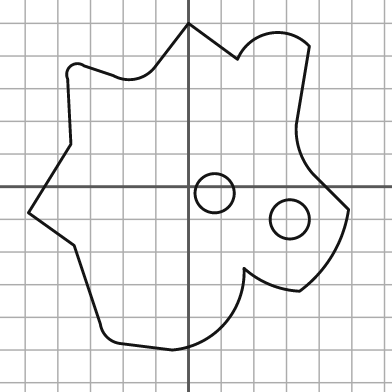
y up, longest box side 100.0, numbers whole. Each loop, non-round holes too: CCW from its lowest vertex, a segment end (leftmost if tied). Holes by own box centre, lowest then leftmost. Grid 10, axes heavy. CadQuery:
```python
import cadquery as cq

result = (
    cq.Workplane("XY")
    .moveTo(-5.0, -50.0)
    .threePointArc((11.0, -42.0), (17.0, -25.0))
    .threePointArc((25.0, -30.0), (34.0, -32.0))
    .threePointArc((44.0, -21.0), (49.0, -7.0))
    .lineTo(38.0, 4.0)
    .threePointArc((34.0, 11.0), (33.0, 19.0))
    .lineTo(37.0, 43.0)
    .threePointArc((25.0, 47.0), (15.0, 39.0))
    .lineTo(0.0, 50.0)
    .lineTo(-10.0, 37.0)
    .threePointArc((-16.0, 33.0), (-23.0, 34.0))
    .lineTo(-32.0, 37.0)
    .threePointArc((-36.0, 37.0), (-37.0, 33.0))
    .lineTo(-36.0, 13.0)
    .lineTo(-49.0, -8.0)
    .lineTo(-35.0, -18.0)
    .lineTo(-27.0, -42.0)
    .threePointArc((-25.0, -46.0), (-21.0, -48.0))
    .close()
    .moveTo(31.0, -10.0)
    .circle(6.0)
    .moveTo(8.0, -2.0)
    .circle(6.0)
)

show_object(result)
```